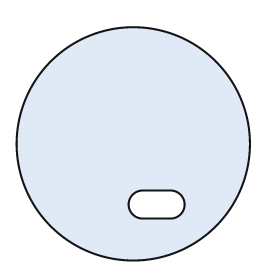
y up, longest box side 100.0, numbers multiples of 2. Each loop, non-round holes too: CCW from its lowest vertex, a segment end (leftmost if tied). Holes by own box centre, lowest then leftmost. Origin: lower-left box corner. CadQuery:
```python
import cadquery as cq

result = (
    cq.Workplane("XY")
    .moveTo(50.0, 50.0)
    .circle(50.0)
    .moveTo(54.0, 18.0)
    .lineTo(66.0, 18.0)
    .threePointArc((72.0, 24.0), (66.0, 30.0))
    .lineTo(54.0, 30.0)
    .threePointArc((48.0, 24.0), (54.0, 18.0))
    .close()
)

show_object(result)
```